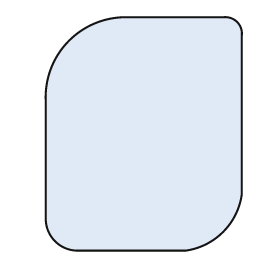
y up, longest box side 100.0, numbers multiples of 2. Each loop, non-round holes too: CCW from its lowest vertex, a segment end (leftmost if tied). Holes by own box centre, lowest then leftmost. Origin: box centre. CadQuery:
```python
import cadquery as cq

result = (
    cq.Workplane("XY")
    .moveTo(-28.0, -50.0)
    .lineTo(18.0, -50.0)
    .threePointArc((34.0, -42.0), (42.0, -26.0))
    .lineTo(42.0, 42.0)
    .threePointArc((40.0, 48.0), (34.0, 50.0))
    .lineTo(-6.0, 50.0)
    .threePointArc((-32.0, 40.0), (-42.0, 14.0))
    .lineTo(-42.0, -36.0)
    .threePointArc((-38.0, -46.0), (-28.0, -50.0))
    .close()
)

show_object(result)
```